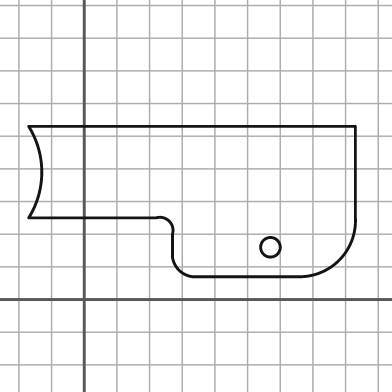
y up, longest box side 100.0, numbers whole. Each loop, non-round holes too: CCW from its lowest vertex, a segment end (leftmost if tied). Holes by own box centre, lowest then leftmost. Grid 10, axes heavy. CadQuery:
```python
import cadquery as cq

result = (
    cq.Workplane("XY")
    .moveTo(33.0, 7.0)
    .lineTo(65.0, 7.0)
    .threePointArc((78.0, 12.0), (83.0, 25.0))
    .lineTo(83.0, 53.0)
    .lineTo(-17.0, 53.0)
    .threePointArc((-13.0, 39.0), (-17.0, 25.0))
    .lineTo(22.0, 25.0)
    .threePointArc((26.0, 24.0), (27.0, 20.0))
    .lineTo(27.0, 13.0)
    .threePointArc((29.0, 9.0), (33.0, 7.0))
    .close()
    .moveTo(57.0, 16.0)
    .circle(3.0)
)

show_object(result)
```